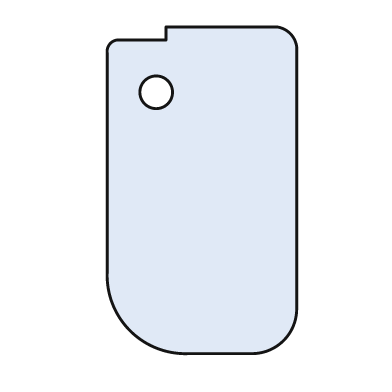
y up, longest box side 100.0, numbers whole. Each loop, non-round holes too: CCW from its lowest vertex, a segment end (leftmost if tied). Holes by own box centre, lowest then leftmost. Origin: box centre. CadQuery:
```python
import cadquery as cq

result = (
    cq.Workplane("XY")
    .moveTo(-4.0, -50.0)
    .lineTo(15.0, -50.0)
    .threePointArc((25.0, -46.0), (29.0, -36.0))
    .lineTo(29.0, 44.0)
    .threePointArc((27.0, 48.0), (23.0, 50.0))
    .lineTo(-11.0, 50.0)
    .lineTo(-11.0, 46.0)
    .lineTo(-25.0, 46.0)
    .threePointArc((-28.0, 45.0), (-29.0, 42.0))
    .lineTo(-29.0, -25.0)
    .threePointArc((-22.0, -43.0), (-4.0, -50.0))
    .close()
    .moveTo(-14.0, 30.0)
    .circle(5.0)
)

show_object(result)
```